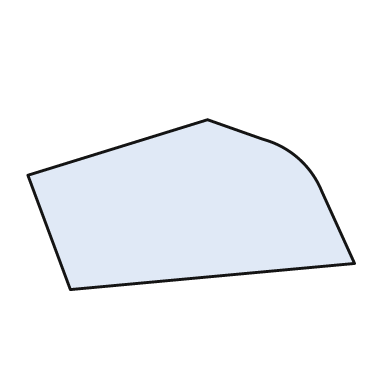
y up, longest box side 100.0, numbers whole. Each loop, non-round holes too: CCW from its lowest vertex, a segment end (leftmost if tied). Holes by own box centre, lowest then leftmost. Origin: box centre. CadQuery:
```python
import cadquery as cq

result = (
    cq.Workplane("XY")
    .moveTo(-37.0, -26.0)
    .lineTo(50.0, -18.0)
    .lineTo(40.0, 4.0)
    .threePointArc((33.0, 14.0), (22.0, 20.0))
    .lineTo(5.0, 26.0)
    .lineTo(-50.0, 9.0)
    .close()
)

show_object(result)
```